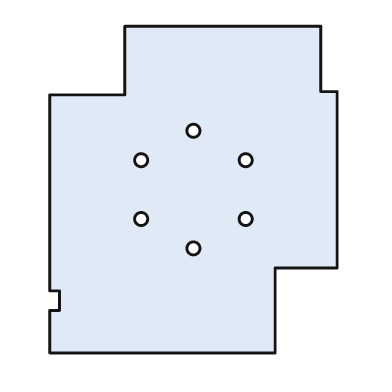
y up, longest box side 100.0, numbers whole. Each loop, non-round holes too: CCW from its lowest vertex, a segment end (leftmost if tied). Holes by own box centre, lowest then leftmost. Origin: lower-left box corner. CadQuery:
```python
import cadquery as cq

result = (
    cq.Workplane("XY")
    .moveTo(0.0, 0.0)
    .lineTo(69.0, 0.0)
    .lineTo(69.0, 26.0)
    .lineTo(88.0, 26.0)
    .lineTo(88.0, 80.0)
    .lineTo(83.0, 80.0)
    .lineTo(83.0, 100.0)
    .lineTo(23.0, 100.0)
    .lineTo(23.0, 79.0)
    .lineTo(0.0, 79.0)
    .lineTo(0.0, 19.0)
    .lineTo(3.0, 19.0)
    .lineTo(3.0, 13.0)
    .lineTo(0.0, 13.0)
    .close()
    .moveTo(44.0, 32.0)
    .circle(2.0)
    .moveTo(28.0, 41.0)
    .circle(2.0)
    .moveTo(60.0, 41.0)
    .circle(2.0)
    .moveTo(28.0, 59.0)
    .circle(2.0)
    .moveTo(60.0, 59.0)
    .circle(2.0)
    .moveTo(44.0, 68.0)
    .circle(2.0)
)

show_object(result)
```